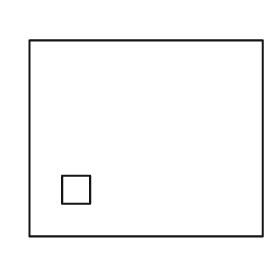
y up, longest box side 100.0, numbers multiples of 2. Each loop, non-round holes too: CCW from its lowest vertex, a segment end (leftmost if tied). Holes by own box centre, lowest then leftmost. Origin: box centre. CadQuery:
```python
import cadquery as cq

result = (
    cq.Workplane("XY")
    .moveTo(-50.0, -42.0)
    .lineTo(50.0, -42.0)
    .lineTo(50.0, 42.0)
    .lineTo(-50.0, 42.0)
    .close()
    .moveTo(-36.0, -28.0)
    .lineTo(-24.0, -28.0)
    .lineTo(-24.0, -16.0)
    .lineTo(-36.0, -16.0)
    .close()
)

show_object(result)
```